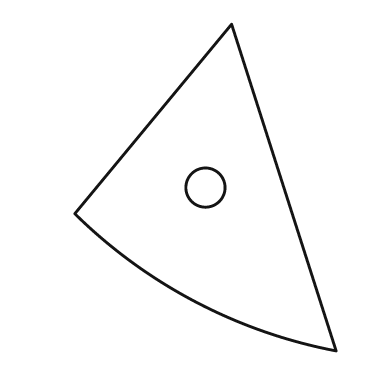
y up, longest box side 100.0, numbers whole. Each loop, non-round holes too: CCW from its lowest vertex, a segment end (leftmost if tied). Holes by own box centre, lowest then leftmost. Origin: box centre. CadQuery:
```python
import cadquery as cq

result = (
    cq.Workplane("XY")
    .moveTo(40.0, -50.0)
    .lineTo(8.0, 50.0)
    .lineTo(-40.0, -8.0)
    .threePointArc((-3.0, -35.0), (40.0, -50.0))
    .close()
    .moveTo(0.0, 0.0)
    .circle(6.0)
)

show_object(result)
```